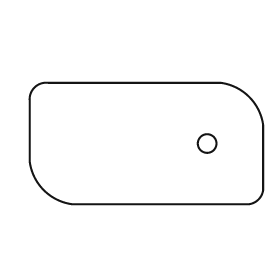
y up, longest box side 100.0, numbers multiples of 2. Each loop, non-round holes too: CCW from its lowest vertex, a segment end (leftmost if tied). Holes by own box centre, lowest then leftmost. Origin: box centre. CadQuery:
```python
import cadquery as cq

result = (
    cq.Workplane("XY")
    .moveTo(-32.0, -26.0)
    .lineTo(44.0, -26.0)
    .threePointArc((48.0, -24.0), (50.0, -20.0))
    .lineTo(50.0, 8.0)
    .threePointArc((44.0, 20.0), (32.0, 26.0))
    .lineTo(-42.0, 26.0)
    .threePointArc((-48.0, 24.0), (-50.0, 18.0))
    .lineTo(-50.0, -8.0)
    .threePointArc((-44.0, -20.0), (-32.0, -26.0))
    .close()
    .moveTo(26.0, 0.0)
    .circle(4.0)
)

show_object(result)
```